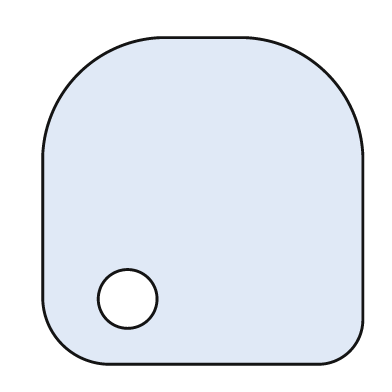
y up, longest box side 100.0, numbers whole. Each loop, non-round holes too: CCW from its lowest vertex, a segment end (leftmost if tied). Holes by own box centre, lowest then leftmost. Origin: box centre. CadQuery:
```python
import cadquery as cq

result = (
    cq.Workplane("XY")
    .moveTo(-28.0, -50.0)
    .lineTo(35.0, -50.0)
    .threePointArc((45.0, -46.0), (49.0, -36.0))
    .lineTo(49.0, 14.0)
    .threePointArc((38.0, 39.0), (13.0, 50.0))
    .lineTo(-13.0, 50.0)
    .threePointArc((-38.0, 39.0), (-49.0, 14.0))
    .lineTo(-49.0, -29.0)
    .threePointArc((-43.0, -44.0), (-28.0, -50.0))
    .close()
    .moveTo(-23.0, -30.0)
    .circle(9.0)
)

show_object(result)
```